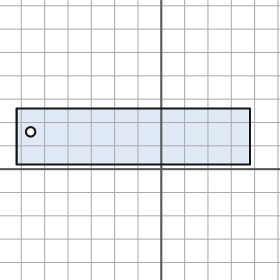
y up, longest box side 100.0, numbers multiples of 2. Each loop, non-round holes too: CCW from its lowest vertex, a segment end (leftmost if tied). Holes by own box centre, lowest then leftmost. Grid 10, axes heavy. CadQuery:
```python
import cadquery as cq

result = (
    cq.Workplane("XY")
    .moveTo(-62.0, 2.0)
    .lineTo(38.0, 2.0)
    .lineTo(38.0, 26.0)
    .lineTo(-62.0, 26.0)
    .close()
    .moveTo(-56.0, 16.0)
    .circle(2.0)
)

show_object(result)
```